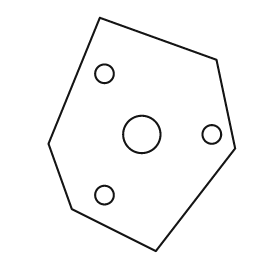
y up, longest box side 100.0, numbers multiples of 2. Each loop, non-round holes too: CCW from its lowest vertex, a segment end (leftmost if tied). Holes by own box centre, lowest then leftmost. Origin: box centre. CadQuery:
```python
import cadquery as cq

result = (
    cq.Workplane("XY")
    .moveTo(6.0, -50.0)
    .lineTo(40.0, -6.0)
    .lineTo(32.0, 32.0)
    .lineTo(-18.0, 50.0)
    .lineTo(-40.0, -4.0)
    .lineTo(-30.0, -32.0)
    .close()
    .moveTo(-16.0, -26.0)
    .circle(4.0)
    .moveTo(0.0, 0.0)
    .circle(8.0)
    .moveTo(30.0, 0.0)
    .circle(4.0)
    .moveTo(-16.0, 26.0)
    .circle(4.0)
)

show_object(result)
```